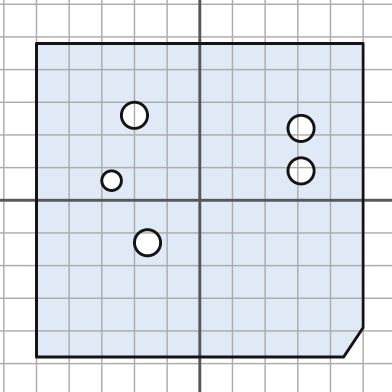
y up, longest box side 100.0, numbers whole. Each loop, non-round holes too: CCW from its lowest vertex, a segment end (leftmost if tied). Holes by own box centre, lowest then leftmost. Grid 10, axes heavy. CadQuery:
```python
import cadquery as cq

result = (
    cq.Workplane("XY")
    .moveTo(-50.0, -48.0)
    .lineTo(44.0, -48.0)
    .lineTo(50.0, -39.0)
    .lineTo(50.0, 48.0)
    .lineTo(-50.0, 48.0)
    .close()
    .moveTo(-16.0, -13.0)
    .circle(4.0)
    .moveTo(-27.0, 6.0)
    .circle(3.0)
    .moveTo(31.0, 9.0)
    .circle(4.0)
    .moveTo(31.0, 22.0)
    .circle(4.0)
    .moveTo(-20.0, 26.0)
    .circle(4.0)
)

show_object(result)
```